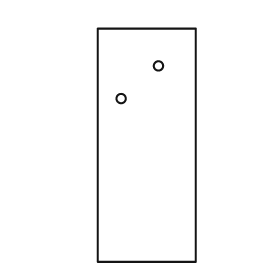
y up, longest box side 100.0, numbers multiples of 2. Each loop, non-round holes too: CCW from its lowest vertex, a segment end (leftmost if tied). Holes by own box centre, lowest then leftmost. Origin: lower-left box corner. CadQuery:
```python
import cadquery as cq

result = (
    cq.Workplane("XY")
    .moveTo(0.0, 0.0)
    .lineTo(42.0, 0.0)
    .lineTo(42.0, 100.0)
    .lineTo(0.0, 100.0)
    .close()
    .moveTo(10.0, 70.0)
    .circle(2.0)
    .moveTo(26.0, 84.0)
    .circle(2.0)
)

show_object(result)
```